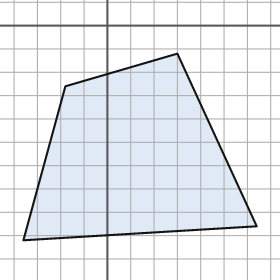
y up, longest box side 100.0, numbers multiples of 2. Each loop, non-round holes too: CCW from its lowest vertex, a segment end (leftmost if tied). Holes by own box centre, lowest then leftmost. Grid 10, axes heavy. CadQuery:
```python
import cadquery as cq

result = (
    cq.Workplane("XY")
    .moveTo(-36.0, -92.0)
    .lineTo(64.0, -86.0)
    .lineTo(30.0, -12.0)
    .lineTo(-18.0, -26.0)
    .close()
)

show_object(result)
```